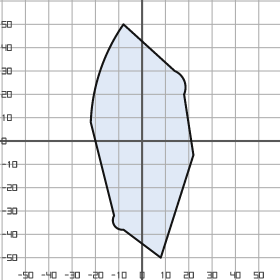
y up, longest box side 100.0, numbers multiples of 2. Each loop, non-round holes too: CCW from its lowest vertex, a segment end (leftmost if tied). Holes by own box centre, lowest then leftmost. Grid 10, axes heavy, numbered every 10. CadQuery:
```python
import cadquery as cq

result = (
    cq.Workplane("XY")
    .moveTo(8.0, -50.0)
    .lineTo(22.0, -6.0)
    .lineTo(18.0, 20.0)
    .threePointArc((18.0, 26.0), (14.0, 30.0))
    .lineTo(-8.0, 50.0)
    .threePointArc((-18.0, 30.0), (-22.0, 8.0))
    .lineTo(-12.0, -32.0)
    .threePointArc((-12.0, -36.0), (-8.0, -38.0))
    .close()
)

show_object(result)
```